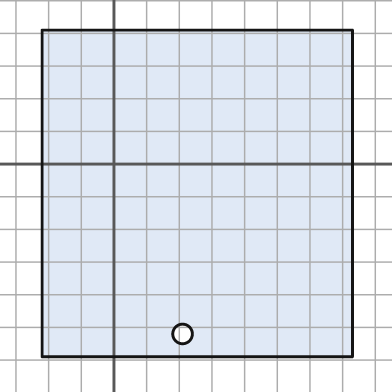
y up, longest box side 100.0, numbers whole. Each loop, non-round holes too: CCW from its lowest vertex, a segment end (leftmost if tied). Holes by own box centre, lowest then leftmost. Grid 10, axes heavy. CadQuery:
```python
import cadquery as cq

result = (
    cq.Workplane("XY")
    .moveTo(-22.0, -59.0)
    .lineTo(73.0, -59.0)
    .lineTo(73.0, 41.0)
    .lineTo(-22.0, 41.0)
    .close()
    .moveTo(21.0, -52.0)
    .circle(3.0)
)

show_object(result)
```